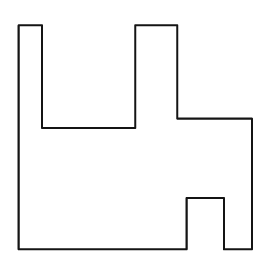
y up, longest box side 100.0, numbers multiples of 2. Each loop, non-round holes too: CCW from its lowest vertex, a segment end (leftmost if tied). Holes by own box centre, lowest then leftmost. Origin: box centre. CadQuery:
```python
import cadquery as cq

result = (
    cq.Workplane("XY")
    .moveTo(-50.0, -48.0)
    .lineTo(22.0, -48.0)
    .lineTo(22.0, -26.0)
    .lineTo(38.0, -26.0)
    .lineTo(38.0, -48.0)
    .lineTo(50.0, -48.0)
    .lineTo(50.0, 8.0)
    .lineTo(18.0, 8.0)
    .lineTo(18.0, 48.0)
    .lineTo(0.0, 48.0)
    .lineTo(0.0, 4.0)
    .lineTo(-40.0, 4.0)
    .lineTo(-40.0, 48.0)
    .lineTo(-50.0, 48.0)
    .close()
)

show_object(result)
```